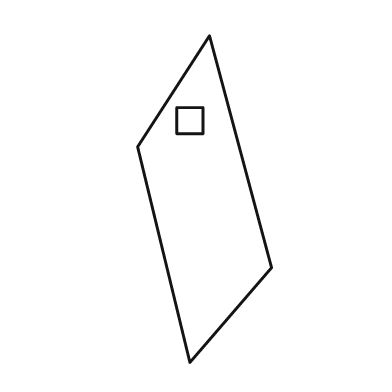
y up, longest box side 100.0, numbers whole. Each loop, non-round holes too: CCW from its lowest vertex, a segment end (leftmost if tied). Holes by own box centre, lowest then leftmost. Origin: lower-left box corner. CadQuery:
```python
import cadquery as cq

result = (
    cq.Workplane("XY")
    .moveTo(16.0, 0.0)
    .lineTo(41.0, 29.0)
    .lineTo(22.0, 100.0)
    .lineTo(0.0, 66.0)
    .close()
    .moveTo(12.0, 70.0)
    .lineTo(20.0, 70.0)
    .lineTo(20.0, 78.0)
    .lineTo(12.0, 78.0)
    .close()
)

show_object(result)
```